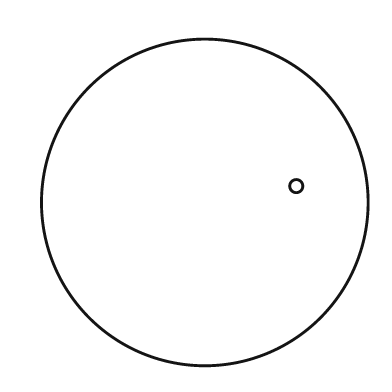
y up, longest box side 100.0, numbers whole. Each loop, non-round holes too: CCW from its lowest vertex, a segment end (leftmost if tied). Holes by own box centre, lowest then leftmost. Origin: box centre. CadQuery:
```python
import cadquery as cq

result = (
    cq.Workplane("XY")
    .moveTo(0.0, 0.0)
    .circle(50.0)
    .moveTo(28.0, 5.0)
    .circle(2.0)
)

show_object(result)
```